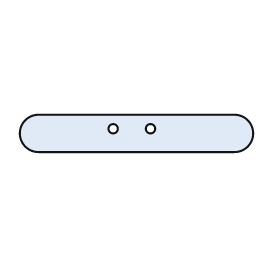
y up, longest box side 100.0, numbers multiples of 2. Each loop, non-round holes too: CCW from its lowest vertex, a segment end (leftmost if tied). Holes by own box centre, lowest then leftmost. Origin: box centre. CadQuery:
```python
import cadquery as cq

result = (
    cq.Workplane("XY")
    .moveTo(-42.0, -8.0)
    .lineTo(42.0, -8.0)
    .threePointArc((50.0, 0.0), (42.0, 8.0))
    .lineTo(-42.0, 8.0)
    .threePointArc((-50.0, 0.0), (-42.0, -8.0))
    .close()
    .moveTo(-10.0, 2.0)
    .circle(2.0)
    .moveTo(6.0, 2.0)
    .circle(2.0)
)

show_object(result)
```